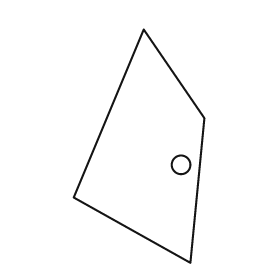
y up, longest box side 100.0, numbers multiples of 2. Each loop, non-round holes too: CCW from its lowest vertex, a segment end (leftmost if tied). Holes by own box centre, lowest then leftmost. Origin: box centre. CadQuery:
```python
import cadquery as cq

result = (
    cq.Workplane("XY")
    .moveTo(22.0, -50.0)
    .lineTo(28.0, 12.0)
    .lineTo(2.0, 50.0)
    .lineTo(-28.0, -22.0)
    .close()
    .moveTo(18.0, -8.0)
    .circle(4.0)
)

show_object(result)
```